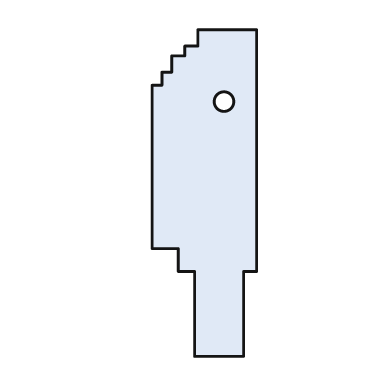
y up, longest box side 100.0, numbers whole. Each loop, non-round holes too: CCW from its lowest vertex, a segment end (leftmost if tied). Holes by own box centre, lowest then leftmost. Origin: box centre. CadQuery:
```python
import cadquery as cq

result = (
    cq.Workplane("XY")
    .moveTo(-3.0, -50.0)
    .lineTo(12.0, -50.0)
    .lineTo(12.0, -24.0)
    .lineTo(16.0, -24.0)
    .lineTo(16.0, 50.0)
    .lineTo(-2.0, 50.0)
    .lineTo(-2.0, 45.0)
    .lineTo(-6.0, 45.0)
    .lineTo(-6.0, 42.0)
    .lineTo(-10.0, 42.0)
    .lineTo(-10.0, 37.0)
    .lineTo(-13.0, 37.0)
    .lineTo(-13.0, 33.0)
    .lineTo(-16.0, 33.0)
    .lineTo(-16.0, -17.0)
    .lineTo(-8.0, -17.0)
    .lineTo(-8.0, -24.0)
    .lineTo(-3.0, -24.0)
    .close()
    .moveTo(6.0, 28.0)
    .circle(3.0)
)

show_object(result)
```